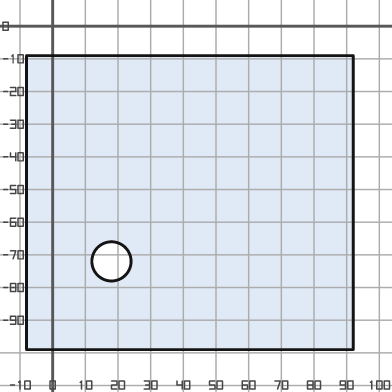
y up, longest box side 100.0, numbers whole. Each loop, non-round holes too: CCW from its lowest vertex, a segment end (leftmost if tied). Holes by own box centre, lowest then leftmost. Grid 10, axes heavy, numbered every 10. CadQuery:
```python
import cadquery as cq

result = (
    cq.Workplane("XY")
    .moveTo(-8.0, -99.0)
    .lineTo(92.0, -99.0)
    .lineTo(92.0, -9.0)
    .lineTo(-8.0, -9.0)
    .close()
    .moveTo(18.0, -72.0)
    .circle(6.0)
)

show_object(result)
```